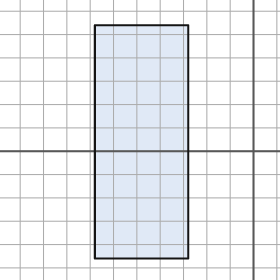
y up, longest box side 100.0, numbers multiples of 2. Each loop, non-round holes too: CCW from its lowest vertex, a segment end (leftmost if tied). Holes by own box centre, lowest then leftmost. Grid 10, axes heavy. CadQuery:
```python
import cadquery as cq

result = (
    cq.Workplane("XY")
    .moveTo(-68.0, -46.0)
    .lineTo(-28.0, -46.0)
    .lineTo(-28.0, 54.0)
    .lineTo(-68.0, 54.0)
    .close()
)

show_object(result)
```